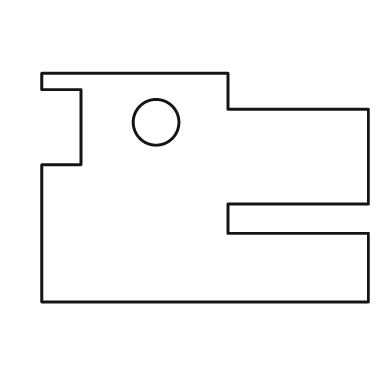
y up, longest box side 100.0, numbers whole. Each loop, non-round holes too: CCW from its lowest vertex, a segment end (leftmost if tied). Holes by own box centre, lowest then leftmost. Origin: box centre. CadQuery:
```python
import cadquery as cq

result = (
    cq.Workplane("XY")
    .moveTo(-50.0, -35.0)
    .lineTo(50.0, -35.0)
    .lineTo(50.0, -14.0)
    .lineTo(7.0, -14.0)
    .lineTo(7.0, -5.0)
    .lineTo(50.0, -5.0)
    .lineTo(50.0, 24.0)
    .lineTo(7.0, 24.0)
    .lineTo(7.0, 35.0)
    .lineTo(-50.0, 35.0)
    .lineTo(-50.0, 30.0)
    .lineTo(-38.0, 30.0)
    .lineTo(-38.0, 7.0)
    .lineTo(-50.0, 7.0)
    .close()
    .moveTo(-15.0, 20.0)
    .circle(7.0)
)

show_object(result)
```